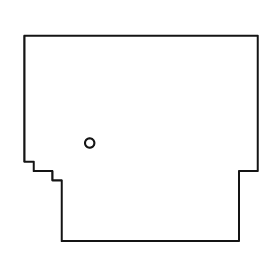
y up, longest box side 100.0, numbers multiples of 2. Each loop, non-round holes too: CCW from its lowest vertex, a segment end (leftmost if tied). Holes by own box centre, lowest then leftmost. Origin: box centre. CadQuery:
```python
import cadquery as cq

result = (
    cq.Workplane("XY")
    .moveTo(-34.0, -44.0)
    .lineTo(42.0, -44.0)
    .lineTo(42.0, -14.0)
    .lineTo(50.0, -14.0)
    .lineTo(50.0, 44.0)
    .lineTo(-50.0, 44.0)
    .lineTo(-50.0, -10.0)
    .lineTo(-46.0, -10.0)
    .lineTo(-46.0, -14.0)
    .lineTo(-38.0, -14.0)
    .lineTo(-38.0, -18.0)
    .lineTo(-34.0, -18.0)
    .close()
    .moveTo(-22.0, -2.0)
    .circle(2.0)
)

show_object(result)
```